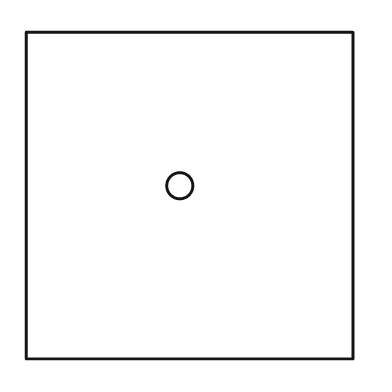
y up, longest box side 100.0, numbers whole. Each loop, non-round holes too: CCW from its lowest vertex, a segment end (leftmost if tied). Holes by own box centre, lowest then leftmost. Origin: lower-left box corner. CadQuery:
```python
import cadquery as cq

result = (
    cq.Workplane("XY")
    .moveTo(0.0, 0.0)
    .lineTo(100.0, 0.0)
    .lineTo(100.0, 100.0)
    .lineTo(0.0, 100.0)
    .close()
    .moveTo(47.0, 53.0)
    .circle(4.0)
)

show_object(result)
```